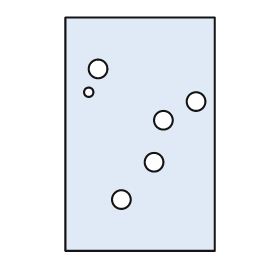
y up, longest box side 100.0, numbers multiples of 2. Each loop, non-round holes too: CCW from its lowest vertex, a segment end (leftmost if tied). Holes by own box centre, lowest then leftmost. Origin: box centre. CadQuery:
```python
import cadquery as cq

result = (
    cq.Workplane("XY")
    .moveTo(-32.0, -50.0)
    .lineTo(32.0, -50.0)
    .lineTo(32.0, 50.0)
    .lineTo(-32.0, 50.0)
    .close()
    .moveTo(-8.0, -28.0)
    .circle(4.0)
    .moveTo(6.0, -12.0)
    .circle(4.0)
    .moveTo(10.0, 6.0)
    .circle(4.0)
    .moveTo(24.0, 14.0)
    .circle(4.0)
    .moveTo(-22.0, 18.0)
    .circle(2.0)
    .moveTo(-18.0, 28.0)
    .circle(4.0)
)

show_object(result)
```